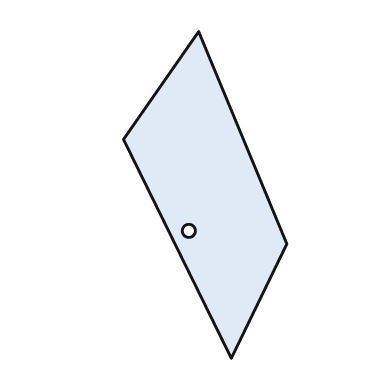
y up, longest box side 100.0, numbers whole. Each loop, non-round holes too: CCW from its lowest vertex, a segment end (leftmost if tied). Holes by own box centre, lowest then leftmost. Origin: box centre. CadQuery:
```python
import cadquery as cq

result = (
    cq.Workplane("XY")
    .moveTo(8.0, -50.0)
    .lineTo(25.0, -15.0)
    .lineTo(-2.0, 50.0)
    .lineTo(-25.0, 17.0)
    .close()
    .moveTo(-5.0, -11.0)
    .circle(2.0)
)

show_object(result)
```